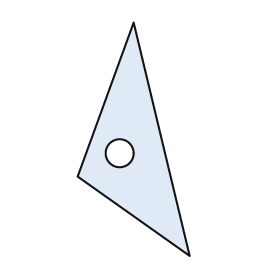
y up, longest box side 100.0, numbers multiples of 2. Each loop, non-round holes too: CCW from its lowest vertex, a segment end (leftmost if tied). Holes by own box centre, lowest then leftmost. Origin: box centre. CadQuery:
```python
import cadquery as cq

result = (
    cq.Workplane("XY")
    .moveTo(24.0, -50.0)
    .lineTo(0.0, 50.0)
    .lineTo(-24.0, -16.0)
    .close()
    .moveTo(-6.0, -6.0)
    .circle(6.0)
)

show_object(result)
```